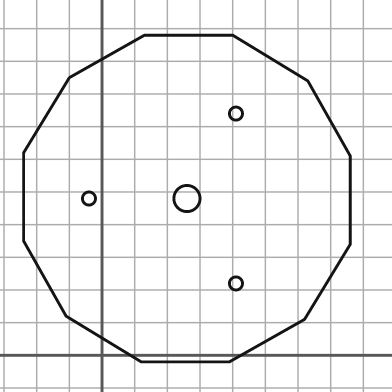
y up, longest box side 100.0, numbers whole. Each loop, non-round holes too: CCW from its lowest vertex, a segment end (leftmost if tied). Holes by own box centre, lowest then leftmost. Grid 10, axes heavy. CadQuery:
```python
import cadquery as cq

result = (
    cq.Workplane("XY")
    .moveTo(12.0, -2.0)
    .lineTo(39.0, -2.0)
    .lineTo(62.0, 11.0)
    .lineTo(76.0, 34.0)
    .lineTo(76.0, 61.0)
    .lineTo(63.0, 84.0)
    .lineTo(40.0, 98.0)
    .lineTo(13.0, 98.0)
    .lineTo(-10.0, 85.0)
    .lineTo(-24.0, 62.0)
    .lineTo(-24.0, 35.0)
    .lineTo(-11.0, 12.0)
    .close()
    .moveTo(41.0, 22.0)
    .circle(2.0)
    .moveTo(-4.0, 48.0)
    .circle(2.0)
    .moveTo(26.0, 48.0)
    .circle(4.0)
    .moveTo(41.0, 74.0)
    .circle(2.0)
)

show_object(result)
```